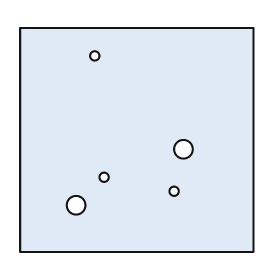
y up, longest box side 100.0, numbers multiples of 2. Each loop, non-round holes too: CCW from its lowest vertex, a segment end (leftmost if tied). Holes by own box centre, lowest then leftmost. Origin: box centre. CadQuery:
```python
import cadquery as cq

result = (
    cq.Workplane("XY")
    .moveTo(-50.0, -48.0)
    .lineTo(50.0, -48.0)
    .lineTo(50.0, 48.0)
    .lineTo(-50.0, 48.0)
    .close()
    .moveTo(-26.0, -28.0)
    .circle(4.0)
    .moveTo(16.0, -22.0)
    .circle(2.0)
    .moveTo(-14.0, -16.0)
    .circle(2.0)
    .moveTo(20.0, -4.0)
    .circle(4.0)
    .moveTo(-18.0, 36.0)
    .circle(2.0)
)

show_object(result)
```